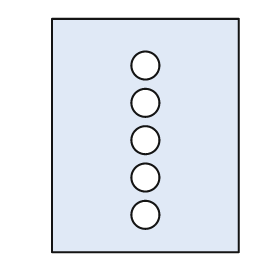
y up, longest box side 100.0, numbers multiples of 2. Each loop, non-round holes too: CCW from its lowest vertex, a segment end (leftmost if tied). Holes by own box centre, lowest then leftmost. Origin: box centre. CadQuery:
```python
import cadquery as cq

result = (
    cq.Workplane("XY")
    .moveTo(-40.0, -50.0)
    .lineTo(40.0, -50.0)
    .lineTo(40.0, 50.0)
    .lineTo(-40.0, 50.0)
    .close()
    .moveTo(0.0, -34.0)
    .circle(6.0)
    .moveTo(0.0, -18.0)
    .circle(6.0)
    .moveTo(0.0, -2.0)
    .circle(6.0)
    .moveTo(0.0, 14.0)
    .circle(6.0)
    .moveTo(0.0, 30.0)
    .circle(6.0)
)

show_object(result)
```